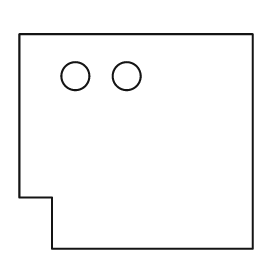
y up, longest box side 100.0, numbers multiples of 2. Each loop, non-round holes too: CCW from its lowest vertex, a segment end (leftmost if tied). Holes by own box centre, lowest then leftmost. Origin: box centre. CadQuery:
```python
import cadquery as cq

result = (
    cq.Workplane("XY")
    .moveTo(-36.0, -46.0)
    .lineTo(50.0, -46.0)
    .lineTo(50.0, 46.0)
    .lineTo(-50.0, 46.0)
    .lineTo(-50.0, -24.0)
    .lineTo(-36.0, -24.0)
    .close()
    .moveTo(-26.0, 28.0)
    .circle(6.0)
    .moveTo(-4.0, 28.0)
    .circle(6.0)
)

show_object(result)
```